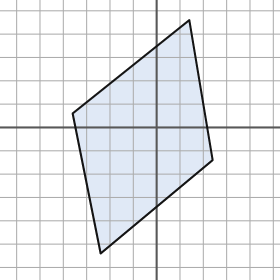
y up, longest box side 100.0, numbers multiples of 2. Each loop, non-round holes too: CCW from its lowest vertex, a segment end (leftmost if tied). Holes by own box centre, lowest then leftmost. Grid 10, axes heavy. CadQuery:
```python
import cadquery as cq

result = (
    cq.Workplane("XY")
    .moveTo(-24.0, -54.0)
    .lineTo(24.0, -14.0)
    .lineTo(14.0, 46.0)
    .lineTo(-36.0, 6.0)
    .close()
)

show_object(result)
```